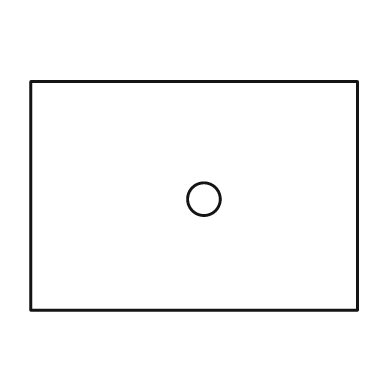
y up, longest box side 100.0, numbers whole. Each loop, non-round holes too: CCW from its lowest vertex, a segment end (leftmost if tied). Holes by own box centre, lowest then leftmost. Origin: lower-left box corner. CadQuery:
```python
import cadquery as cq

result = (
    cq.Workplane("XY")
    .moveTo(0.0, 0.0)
    .lineTo(100.0, 0.0)
    .lineTo(100.0, 70.0)
    .lineTo(0.0, 70.0)
    .close()
    .moveTo(53.0, 34.0)
    .circle(5.0)
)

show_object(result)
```